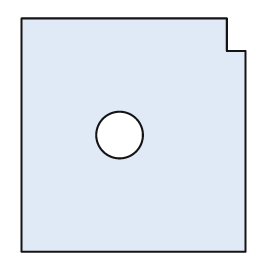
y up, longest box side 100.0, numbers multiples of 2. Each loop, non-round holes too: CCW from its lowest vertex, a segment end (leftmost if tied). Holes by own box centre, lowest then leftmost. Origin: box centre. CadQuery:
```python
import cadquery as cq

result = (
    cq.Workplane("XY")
    .moveTo(-48.0, -50.0)
    .lineTo(48.0, -50.0)
    .lineTo(48.0, 36.0)
    .lineTo(40.0, 36.0)
    .lineTo(40.0, 50.0)
    .lineTo(-48.0, 50.0)
    .close()
    .moveTo(-6.0, 0.0)
    .circle(10.0)
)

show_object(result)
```